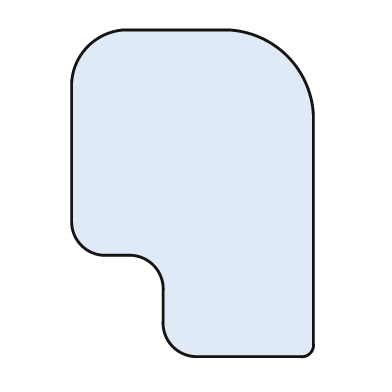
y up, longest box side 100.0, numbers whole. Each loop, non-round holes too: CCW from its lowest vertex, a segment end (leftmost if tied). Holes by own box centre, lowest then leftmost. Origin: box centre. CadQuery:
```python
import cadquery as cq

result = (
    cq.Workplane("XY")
    .moveTo(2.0, -50.0)
    .lineTo(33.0, -50.0)
    .threePointArc((36.0, -49.0), (37.0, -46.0))
    .lineTo(37.0, 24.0)
    .threePointArc((29.0, 42.0), (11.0, 50.0))
    .lineTo(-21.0, 50.0)
    .threePointArc((-32.0, 45.0), (-37.0, 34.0))
    .lineTo(-37.0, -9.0)
    .threePointArc((-34.0, -16.0), (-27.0, -19.0))
    .lineTo(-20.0, -19.0)
    .threePointArc((-12.0, -22.0), (-9.0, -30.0))
    .lineTo(-9.0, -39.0)
    .threePointArc((-6.0, -47.0), (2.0, -50.0))
    .close()
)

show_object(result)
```